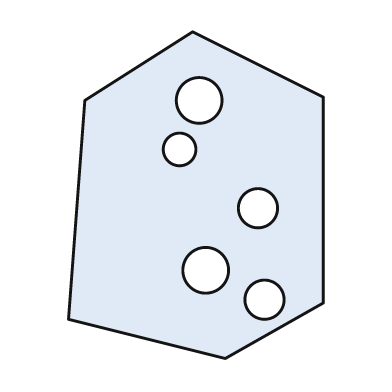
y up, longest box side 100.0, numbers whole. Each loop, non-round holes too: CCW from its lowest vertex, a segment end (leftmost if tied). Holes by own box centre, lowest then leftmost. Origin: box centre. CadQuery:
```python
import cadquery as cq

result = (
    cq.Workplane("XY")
    .moveTo(9.0, -50.0)
    .lineTo(39.0, -33.0)
    .lineTo(39.0, 30.0)
    .lineTo(-1.0, 50.0)
    .lineTo(-34.0, 29.0)
    .lineTo(-39.0, -38.0)
    .close()
    .moveTo(21.0, -32.0)
    .circle(6.0)
    .moveTo(3.0, -23.0)
    .circle(7.0)
    .moveTo(19.0, -4.0)
    .circle(6.0)
    .moveTo(-5.0, 14.0)
    .circle(5.0)
    .moveTo(1.0, 29.0)
    .circle(7.0)
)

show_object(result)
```